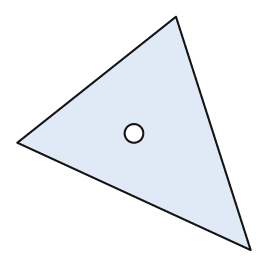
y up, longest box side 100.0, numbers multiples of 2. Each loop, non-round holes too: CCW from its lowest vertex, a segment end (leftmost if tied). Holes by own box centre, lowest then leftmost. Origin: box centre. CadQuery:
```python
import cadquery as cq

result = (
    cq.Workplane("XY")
    .moveTo(50.0, -50.0)
    .lineTo(18.0, 50.0)
    .lineTo(-50.0, -4.0)
    .close()
    .moveTo(0.0, 0.0)
    .circle(4.0)
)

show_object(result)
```